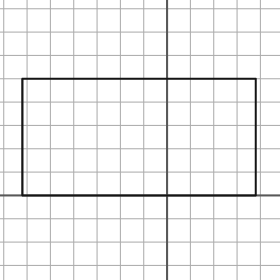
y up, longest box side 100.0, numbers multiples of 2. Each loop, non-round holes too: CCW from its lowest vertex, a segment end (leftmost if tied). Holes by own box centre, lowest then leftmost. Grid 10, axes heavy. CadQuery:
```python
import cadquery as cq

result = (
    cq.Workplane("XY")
    .moveTo(-62.0, 0.0)
    .lineTo(38.0, 0.0)
    .lineTo(38.0, 50.0)
    .lineTo(-62.0, 50.0)
    .close()
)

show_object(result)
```